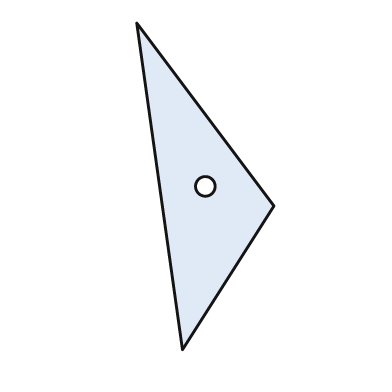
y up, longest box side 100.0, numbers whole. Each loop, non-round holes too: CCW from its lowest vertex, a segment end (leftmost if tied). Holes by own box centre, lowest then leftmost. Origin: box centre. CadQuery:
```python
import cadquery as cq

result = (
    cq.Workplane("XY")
    .moveTo(-7.0, -50.0)
    .lineTo(21.0, -6.0)
    .lineTo(-21.0, 50.0)
    .close()
    .moveTo(0.0, 0.0)
    .circle(3.0)
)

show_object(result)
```